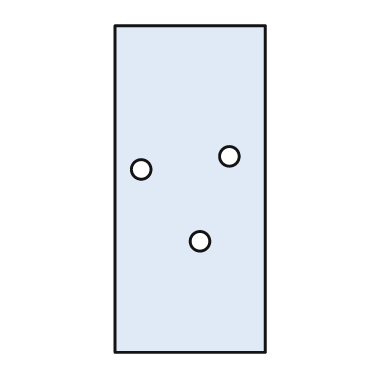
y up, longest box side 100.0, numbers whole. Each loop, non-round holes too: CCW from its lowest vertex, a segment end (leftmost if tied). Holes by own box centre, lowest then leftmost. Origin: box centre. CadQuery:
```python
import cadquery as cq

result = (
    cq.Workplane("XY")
    .moveTo(-23.0, -50.0)
    .lineTo(23.0, -50.0)
    .lineTo(23.0, 50.0)
    .lineTo(-23.0, 50.0)
    .close()
    .moveTo(3.0, -16.0)
    .circle(3.0)
    .moveTo(-15.0, 6.0)
    .circle(3.0)
    .moveTo(12.0, 10.0)
    .circle(3.0)
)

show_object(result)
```